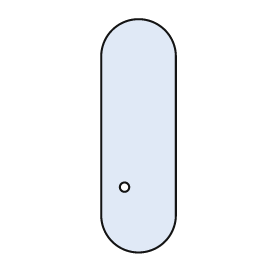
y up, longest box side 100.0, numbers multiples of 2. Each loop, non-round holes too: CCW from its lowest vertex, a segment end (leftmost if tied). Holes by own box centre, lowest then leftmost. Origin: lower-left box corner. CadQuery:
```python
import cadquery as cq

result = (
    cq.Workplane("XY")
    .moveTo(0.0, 16.0)
    .threePointArc((16.0, 0.0), (32.0, 16.0))
    .lineTo(32.0, 84.0)
    .threePointArc((16.0, 100.0), (0.0, 84.0))
    .close()
    .moveTo(10.0, 28.0)
    .circle(2.0)
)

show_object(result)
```